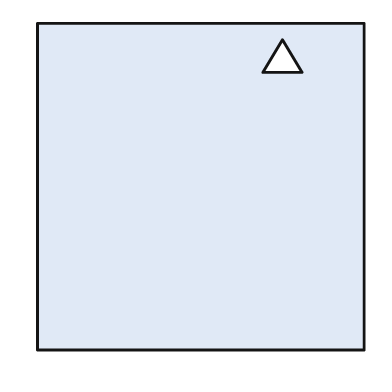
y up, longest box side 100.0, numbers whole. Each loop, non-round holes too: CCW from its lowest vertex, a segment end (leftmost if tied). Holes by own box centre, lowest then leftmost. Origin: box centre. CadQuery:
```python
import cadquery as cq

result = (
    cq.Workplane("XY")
    .moveTo(-50.0, -50.0)
    .lineTo(50.0, -50.0)
    .lineTo(50.0, 50.0)
    .lineTo(-50.0, 50.0)
    .close()
    .moveTo(19.0, 35.0)
    .lineTo(31.0, 35.0)
    .lineTo(25.0, 45.0)
    .close()
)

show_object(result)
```